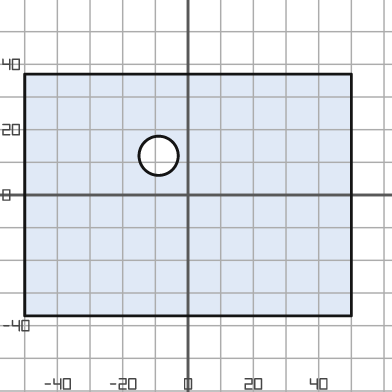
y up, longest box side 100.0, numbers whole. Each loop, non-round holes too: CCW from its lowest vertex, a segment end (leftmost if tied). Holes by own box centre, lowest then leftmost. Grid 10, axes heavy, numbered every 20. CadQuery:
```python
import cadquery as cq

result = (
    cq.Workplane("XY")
    .moveTo(-50.0, -37.0)
    .lineTo(50.0, -37.0)
    .lineTo(50.0, 37.0)
    .lineTo(-50.0, 37.0)
    .close()
    .moveTo(-9.0, 12.0)
    .circle(6.0)
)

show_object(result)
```